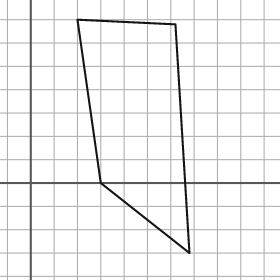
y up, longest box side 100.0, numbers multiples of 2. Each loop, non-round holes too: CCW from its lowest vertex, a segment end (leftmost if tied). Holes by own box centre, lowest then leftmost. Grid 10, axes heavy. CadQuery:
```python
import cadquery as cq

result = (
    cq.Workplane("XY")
    .moveTo(68.0, -30.0)
    .lineTo(62.0, 68.0)
    .lineTo(20.0, 70.0)
    .lineTo(30.0, 0.0)
    .close()
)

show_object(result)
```